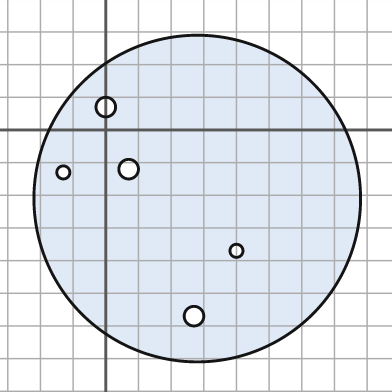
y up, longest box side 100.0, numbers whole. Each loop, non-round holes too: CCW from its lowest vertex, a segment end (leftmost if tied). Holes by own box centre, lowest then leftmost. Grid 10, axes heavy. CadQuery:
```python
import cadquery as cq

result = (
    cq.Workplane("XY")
    .moveTo(28.0, -21.0)
    .circle(50.0)
    .moveTo(27.0, -57.0)
    .circle(3.0)
    .moveTo(40.0, -37.0)
    .circle(2.0)
    .moveTo(-13.0, -13.0)
    .circle(2.0)
    .moveTo(7.0, -12.0)
    .circle(3.0)
    .moveTo(0.0, 7.0)
    .circle(3.0)
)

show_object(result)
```